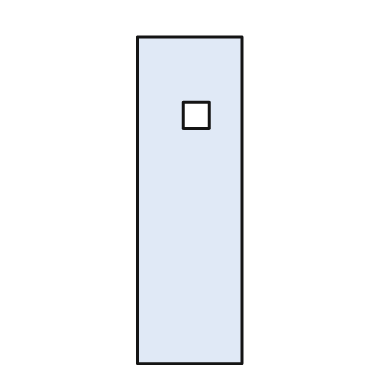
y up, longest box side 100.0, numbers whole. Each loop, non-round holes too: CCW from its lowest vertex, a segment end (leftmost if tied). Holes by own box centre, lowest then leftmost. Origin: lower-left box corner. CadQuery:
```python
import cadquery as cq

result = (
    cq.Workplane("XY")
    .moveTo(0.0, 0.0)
    .lineTo(32.0, 0.0)
    .lineTo(32.0, 100.0)
    .lineTo(0.0, 100.0)
    .close()
    .moveTo(14.0, 72.0)
    .lineTo(22.0, 72.0)
    .lineTo(22.0, 80.0)
    .lineTo(14.0, 80.0)
    .close()
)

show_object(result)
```